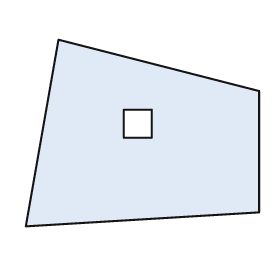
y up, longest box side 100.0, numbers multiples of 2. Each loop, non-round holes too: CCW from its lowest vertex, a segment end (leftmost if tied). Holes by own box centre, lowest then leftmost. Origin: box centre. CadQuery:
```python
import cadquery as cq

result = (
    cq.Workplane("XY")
    .moveTo(-50.0, -40.0)
    .lineTo(50.0, -34.0)
    .lineTo(50.0, 18.0)
    .lineTo(-36.0, 40.0)
    .close()
    .moveTo(-8.0, -2.0)
    .lineTo(4.0, -2.0)
    .lineTo(4.0, 10.0)
    .lineTo(-8.0, 10.0)
    .close()
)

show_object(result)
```